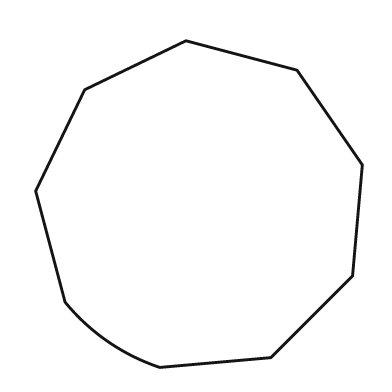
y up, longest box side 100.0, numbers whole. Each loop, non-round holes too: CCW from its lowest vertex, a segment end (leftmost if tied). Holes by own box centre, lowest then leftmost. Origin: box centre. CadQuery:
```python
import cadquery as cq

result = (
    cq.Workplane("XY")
    .moveTo(-12.0, -50.0)
    .lineTo(22.0, -47.0)
    .lineTo(47.0, -22.0)
    .lineTo(50.0, 12.0)
    .lineTo(30.0, 41.0)
    .lineTo(-4.0, 50.0)
    .lineTo(-35.0, 35.0)
    .lineTo(-50.0, 4.0)
    .lineTo(-41.0, -30.0)
    .threePointArc((-28.0, -42.0), (-12.0, -50.0))
    .close()
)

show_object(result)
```